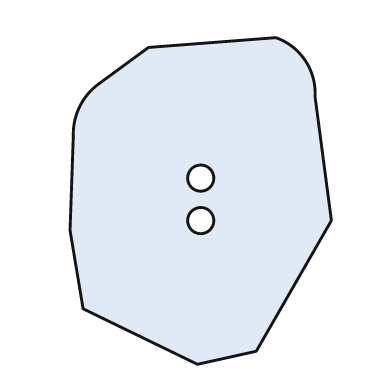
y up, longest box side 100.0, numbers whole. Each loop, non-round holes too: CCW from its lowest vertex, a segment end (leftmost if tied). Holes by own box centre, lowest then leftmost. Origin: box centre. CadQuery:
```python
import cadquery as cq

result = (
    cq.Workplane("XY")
    .moveTo(-1.0, -50.0)
    .lineTo(17.0, -46.0)
    .lineTo(40.0, -6.0)
    .lineTo(35.0, 32.0)
    .threePointArc((32.0, 43.0), (23.0, 50.0))
    .lineTo(-16.0, 47.0)
    .lineTo(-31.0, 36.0)
    .threePointArc((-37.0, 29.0), (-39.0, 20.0))
    .lineTo(-40.0, -9.0)
    .lineTo(-36.0, -33.0)
    .close()
    .moveTo(0.0, -6.0)
    .circle(4.0)
    .moveTo(0.0, 7.0)
    .circle(4.0)
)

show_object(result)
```